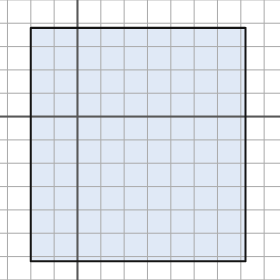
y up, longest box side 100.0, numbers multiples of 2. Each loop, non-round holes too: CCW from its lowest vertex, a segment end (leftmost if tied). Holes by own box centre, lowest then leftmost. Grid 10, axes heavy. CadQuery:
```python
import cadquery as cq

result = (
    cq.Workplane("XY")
    .moveTo(-20.0, -62.0)
    .lineTo(72.0, -62.0)
    .lineTo(72.0, 38.0)
    .lineTo(-20.0, 38.0)
    .close()
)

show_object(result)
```